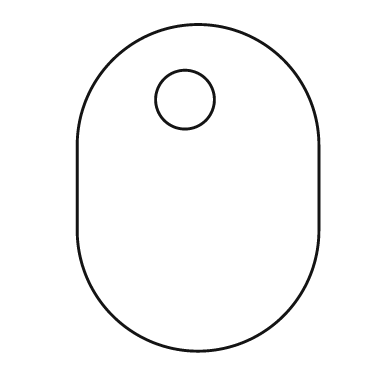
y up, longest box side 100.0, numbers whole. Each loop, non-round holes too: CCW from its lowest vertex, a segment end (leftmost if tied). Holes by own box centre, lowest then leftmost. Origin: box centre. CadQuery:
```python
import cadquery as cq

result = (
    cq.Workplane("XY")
    .moveTo(-37.0, -13.0)
    .threePointArc((0.0, -50.0), (37.0, -13.0))
    .lineTo(37.0, 13.0)
    .threePointArc((0.0, 50.0), (-37.0, 13.0))
    .close()
    .moveTo(-4.0, 27.0)
    .circle(9.0)
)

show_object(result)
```